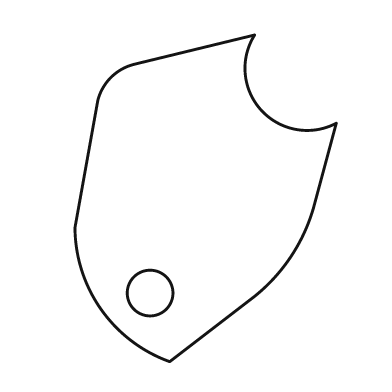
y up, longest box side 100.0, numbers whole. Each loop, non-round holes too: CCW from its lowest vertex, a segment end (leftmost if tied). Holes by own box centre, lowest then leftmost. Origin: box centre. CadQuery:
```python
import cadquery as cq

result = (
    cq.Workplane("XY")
    .moveTo(-11.0, -50.0)
    .lineTo(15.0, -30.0)
    .threePointArc((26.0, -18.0), (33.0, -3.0))
    .lineTo(40.0, 23.0)
    .threePointArc((17.0, 27.0), (15.0, 50.0))
    .lineTo(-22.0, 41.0)
    .threePointArc((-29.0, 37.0), (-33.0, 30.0))
    .lineTo(-40.0, -9.0)
    .threePointArc((-32.0, -34.0), (-11.0, -50.0))
    .close()
    .moveTo(-17.0, -29.0)
    .circle(7.0)
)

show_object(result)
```